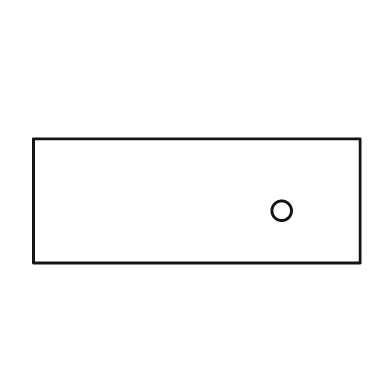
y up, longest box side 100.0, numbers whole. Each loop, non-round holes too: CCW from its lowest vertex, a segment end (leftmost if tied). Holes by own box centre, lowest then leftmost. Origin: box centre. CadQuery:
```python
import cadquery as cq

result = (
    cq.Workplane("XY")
    .moveTo(-50.0, -19.0)
    .lineTo(50.0, -19.0)
    .lineTo(50.0, 19.0)
    .lineTo(-50.0, 19.0)
    .close()
    .moveTo(26.0, -3.0)
    .circle(3.0)
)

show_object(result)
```